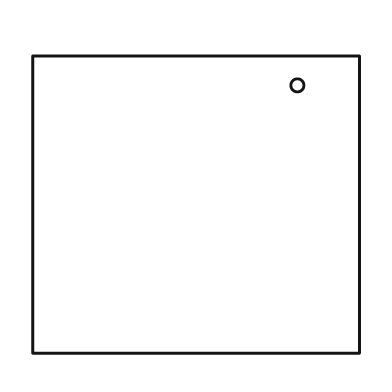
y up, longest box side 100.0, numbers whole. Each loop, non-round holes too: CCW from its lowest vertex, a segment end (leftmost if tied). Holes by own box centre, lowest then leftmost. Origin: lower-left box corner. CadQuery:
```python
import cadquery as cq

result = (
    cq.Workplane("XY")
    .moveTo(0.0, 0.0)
    .lineTo(100.0, 0.0)
    .lineTo(100.0, 91.0)
    .lineTo(0.0, 91.0)
    .close()
    .moveTo(81.0, 82.0)
    .circle(2.0)
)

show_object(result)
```